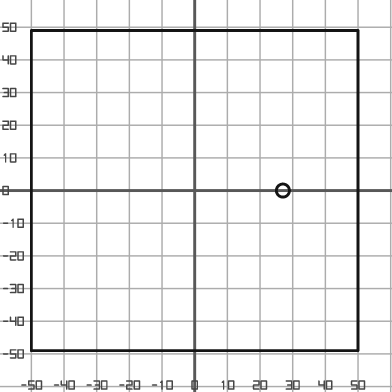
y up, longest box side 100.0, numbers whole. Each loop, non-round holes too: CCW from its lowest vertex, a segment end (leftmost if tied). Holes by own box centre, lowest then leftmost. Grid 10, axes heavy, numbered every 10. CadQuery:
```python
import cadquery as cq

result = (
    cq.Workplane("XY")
    .moveTo(-50.0, -49.0)
    .lineTo(50.0, -49.0)
    .lineTo(50.0, 49.0)
    .lineTo(-50.0, 49.0)
    .close()
    .moveTo(27.0, 0.0)
    .circle(2.0)
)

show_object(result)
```